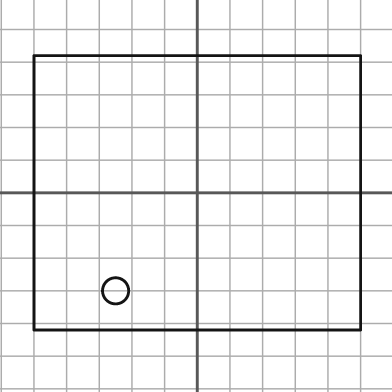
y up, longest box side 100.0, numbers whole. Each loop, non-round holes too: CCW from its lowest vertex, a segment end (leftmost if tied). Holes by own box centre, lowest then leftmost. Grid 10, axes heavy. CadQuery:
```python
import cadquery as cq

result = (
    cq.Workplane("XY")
    .moveTo(-50.0, -42.0)
    .lineTo(50.0, -42.0)
    .lineTo(50.0, 42.0)
    .lineTo(-50.0, 42.0)
    .close()
    .moveTo(-25.0, -30.0)
    .circle(4.0)
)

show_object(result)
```